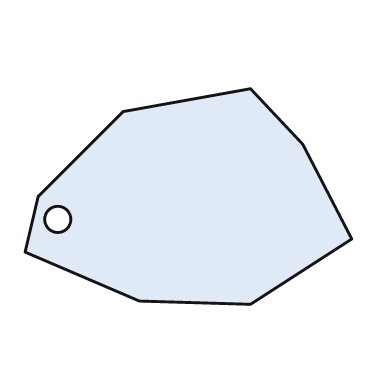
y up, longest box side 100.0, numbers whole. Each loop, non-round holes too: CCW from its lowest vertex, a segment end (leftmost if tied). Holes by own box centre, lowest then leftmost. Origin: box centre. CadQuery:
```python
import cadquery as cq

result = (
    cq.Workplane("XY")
    .moveTo(19.0, -33.0)
    .lineTo(50.0, -13.0)
    .lineTo(35.0, 16.0)
    .lineTo(19.0, 33.0)
    .lineTo(-20.0, 26.0)
    .lineTo(-46.0, 0.0)
    .lineTo(-50.0, -17.0)
    .lineTo(-15.0, -32.0)
    .close()
    .moveTo(-40.0, -7.0)
    .circle(4.0)
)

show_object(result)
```